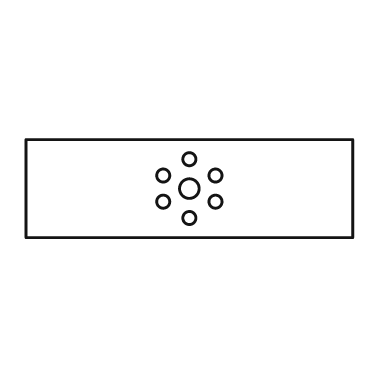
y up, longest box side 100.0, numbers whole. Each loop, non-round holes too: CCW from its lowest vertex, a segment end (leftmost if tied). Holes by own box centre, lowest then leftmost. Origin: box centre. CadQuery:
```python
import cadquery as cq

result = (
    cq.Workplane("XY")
    .moveTo(-50.0, -15.0)
    .lineTo(50.0, -15.0)
    .lineTo(50.0, 15.0)
    .lineTo(-50.0, 15.0)
    .close()
    .moveTo(0.0, -9.0)
    .circle(2.0)
    .moveTo(-8.0, -4.0)
    .circle(2.0)
    .moveTo(8.0, -4.0)
    .circle(2.0)
    .moveTo(0.0, 0.0)
    .circle(3.0)
    .moveTo(-8.0, 4.0)
    .circle(2.0)
    .moveTo(8.0, 4.0)
    .circle(2.0)
    .moveTo(0.0, 9.0)
    .circle(2.0)
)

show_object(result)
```